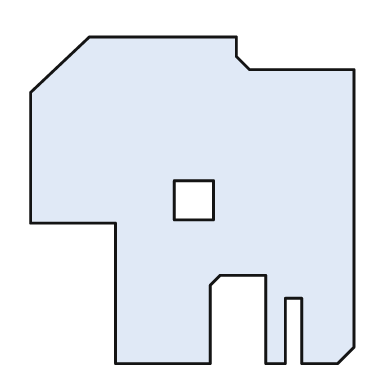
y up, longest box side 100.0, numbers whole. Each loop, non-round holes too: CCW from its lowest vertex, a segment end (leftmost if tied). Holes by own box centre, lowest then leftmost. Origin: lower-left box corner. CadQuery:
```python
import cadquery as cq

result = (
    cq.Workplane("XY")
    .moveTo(26.0, 0.0)
    .lineTo(55.0, 0.0)
    .lineTo(55.0, 24.0)
    .lineTo(58.0, 27.0)
    .lineTo(72.0, 27.0)
    .lineTo(72.0, 0.0)
    .lineTo(78.0, 0.0)
    .lineTo(78.0, 20.0)
    .lineTo(83.0, 20.0)
    .lineTo(83.0, 0.0)
    .lineTo(94.0, 0.0)
    .lineTo(99.0, 5.0)
    .lineTo(99.0, 90.0)
    .lineTo(67.0, 90.0)
    .lineTo(63.0, 94.0)
    .lineTo(63.0, 100.0)
    .lineTo(18.0, 100.0)
    .lineTo(0.0, 83.0)
    .lineTo(0.0, 43.0)
    .lineTo(26.0, 43.0)
    .close()
    .moveTo(44.0, 44.0)
    .lineTo(56.0, 44.0)
    .lineTo(56.0, 56.0)
    .lineTo(44.0, 56.0)
    .close()
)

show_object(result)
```